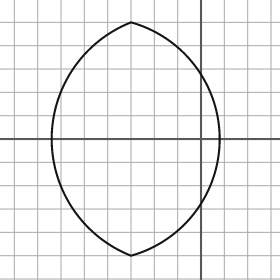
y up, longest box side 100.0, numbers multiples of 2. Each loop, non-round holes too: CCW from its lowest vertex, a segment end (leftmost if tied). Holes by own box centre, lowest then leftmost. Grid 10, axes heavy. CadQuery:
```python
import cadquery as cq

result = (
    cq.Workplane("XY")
    .moveTo(-30.0, -50.0)
    .threePointArc((8.0, 0.0), (-30.0, 50.0))
    .threePointArc((-64.0, 0.0), (-30.0, -50.0))
    .close()
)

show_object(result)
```